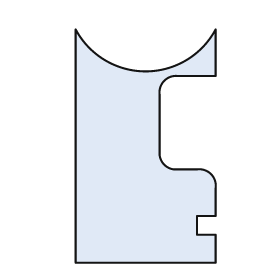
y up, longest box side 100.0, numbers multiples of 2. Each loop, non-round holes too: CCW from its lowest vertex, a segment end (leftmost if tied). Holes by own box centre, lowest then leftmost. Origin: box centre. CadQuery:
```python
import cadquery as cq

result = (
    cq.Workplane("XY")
    .moveTo(-30.0, -50.0)
    .lineTo(30.0, -50.0)
    .lineTo(30.0, -38.0)
    .lineTo(22.0, -38.0)
    .lineTo(22.0, -30.0)
    .lineTo(30.0, -30.0)
    .lineTo(30.0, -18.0)
    .threePointArc((28.0, -12.0), (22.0, -10.0))
    .lineTo(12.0, -10.0)
    .threePointArc((8.0, -8.0), (6.0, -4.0))
    .lineTo(6.0, 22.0)
    .threePointArc((8.0, 28.0), (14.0, 30.0))
    .lineTo(30.0, 30.0)
    .lineTo(30.0, 50.0)
    .threePointArc((0.0, 32.0), (-30.0, 50.0))
    .close()
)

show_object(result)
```